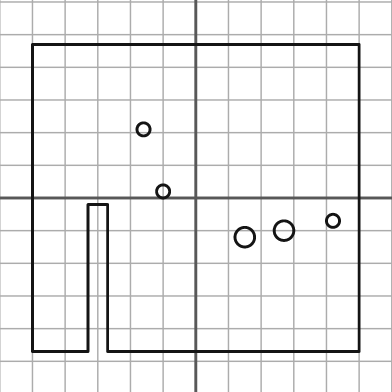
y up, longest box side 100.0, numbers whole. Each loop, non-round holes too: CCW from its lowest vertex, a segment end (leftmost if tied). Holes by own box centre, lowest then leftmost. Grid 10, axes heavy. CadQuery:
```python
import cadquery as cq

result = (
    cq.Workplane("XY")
    .moveTo(-50.0, -47.0)
    .lineTo(-33.0, -47.0)
    .lineTo(-33.0, -2.0)
    .lineTo(-27.0, -2.0)
    .lineTo(-27.0, -47.0)
    .lineTo(50.0, -47.0)
    .lineTo(50.0, 47.0)
    .lineTo(-50.0, 47.0)
    .close()
    .moveTo(15.0, -12.0)
    .circle(3.0)
    .moveTo(27.0, -10.0)
    .circle(3.0)
    .moveTo(42.0, -7.0)
    .circle(2.0)
    .moveTo(-10.0, 2.0)
    .circle(2.0)
    .moveTo(-16.0, 21.0)
    .circle(2.0)
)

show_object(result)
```